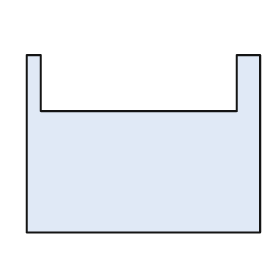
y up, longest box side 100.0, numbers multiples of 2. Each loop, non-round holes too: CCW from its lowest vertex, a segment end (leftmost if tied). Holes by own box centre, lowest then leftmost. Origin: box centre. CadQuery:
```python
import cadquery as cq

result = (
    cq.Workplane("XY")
    .moveTo(-50.0, -38.0)
    .lineTo(50.0, -38.0)
    .lineTo(50.0, 38.0)
    .lineTo(40.0, 38.0)
    .lineTo(40.0, 14.0)
    .lineTo(-44.0, 14.0)
    .lineTo(-44.0, 38.0)
    .lineTo(-50.0, 38.0)
    .close()
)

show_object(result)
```